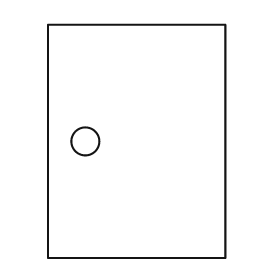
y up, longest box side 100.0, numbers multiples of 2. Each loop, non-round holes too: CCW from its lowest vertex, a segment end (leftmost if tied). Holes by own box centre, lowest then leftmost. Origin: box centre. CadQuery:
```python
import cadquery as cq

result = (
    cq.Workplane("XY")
    .moveTo(-38.0, -50.0)
    .lineTo(38.0, -50.0)
    .lineTo(38.0, 50.0)
    .lineTo(-38.0, 50.0)
    .close()
    .moveTo(-22.0, 0.0)
    .circle(6.0)
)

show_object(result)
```